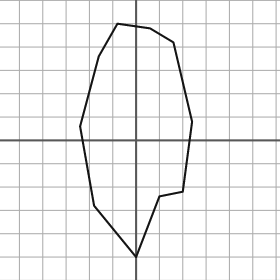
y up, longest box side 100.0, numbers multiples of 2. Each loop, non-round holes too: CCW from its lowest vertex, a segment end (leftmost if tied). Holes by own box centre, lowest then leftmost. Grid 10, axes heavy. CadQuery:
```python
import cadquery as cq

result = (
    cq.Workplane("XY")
    .moveTo(0.0, -50.0)
    .lineTo(10.0, -24.0)
    .lineTo(20.0, -22.0)
    .lineTo(24.0, 8.0)
    .lineTo(16.0, 42.0)
    .lineTo(6.0, 48.0)
    .lineTo(-8.0, 50.0)
    .lineTo(-16.0, 36.0)
    .lineTo(-24.0, 6.0)
    .lineTo(-18.0, -28.0)
    .close()
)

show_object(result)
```